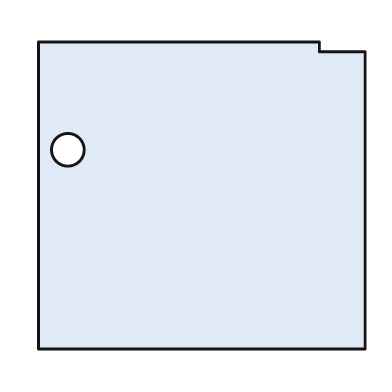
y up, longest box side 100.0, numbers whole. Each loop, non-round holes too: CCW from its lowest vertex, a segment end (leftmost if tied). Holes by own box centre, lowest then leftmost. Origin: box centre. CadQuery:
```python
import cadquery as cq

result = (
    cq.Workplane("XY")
    .moveTo(-50.0, -47.0)
    .lineTo(50.0, -47.0)
    .lineTo(50.0, 44.0)
    .lineTo(36.0, 44.0)
    .lineTo(36.0, 47.0)
    .lineTo(-50.0, 47.0)
    .close()
    .moveTo(-41.0, 14.0)
    .circle(5.0)
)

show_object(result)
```